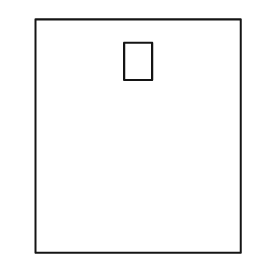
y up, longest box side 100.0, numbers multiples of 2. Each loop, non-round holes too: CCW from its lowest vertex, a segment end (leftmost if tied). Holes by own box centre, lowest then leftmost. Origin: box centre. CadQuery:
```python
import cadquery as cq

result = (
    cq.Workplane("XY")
    .moveTo(-44.0, -50.0)
    .lineTo(44.0, -50.0)
    .lineTo(44.0, 50.0)
    .lineTo(-44.0, 50.0)
    .close()
    .moveTo(-6.0, 24.0)
    .lineTo(6.0, 24.0)
    .lineTo(6.0, 40.0)
    .lineTo(-6.0, 40.0)
    .close()
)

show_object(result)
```